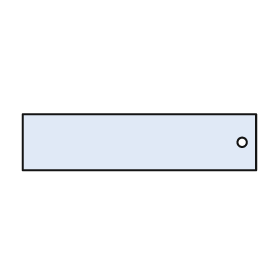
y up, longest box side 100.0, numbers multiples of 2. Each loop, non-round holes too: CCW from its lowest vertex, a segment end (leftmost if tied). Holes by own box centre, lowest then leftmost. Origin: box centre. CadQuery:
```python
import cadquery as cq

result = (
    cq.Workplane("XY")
    .moveTo(-50.0, -12.0)
    .lineTo(50.0, -12.0)
    .lineTo(50.0, 12.0)
    .lineTo(-50.0, 12.0)
    .close()
    .moveTo(44.0, 0.0)
    .circle(2.0)
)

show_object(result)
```